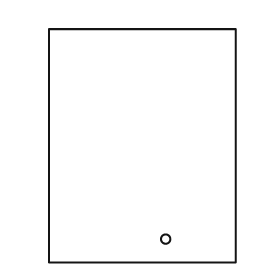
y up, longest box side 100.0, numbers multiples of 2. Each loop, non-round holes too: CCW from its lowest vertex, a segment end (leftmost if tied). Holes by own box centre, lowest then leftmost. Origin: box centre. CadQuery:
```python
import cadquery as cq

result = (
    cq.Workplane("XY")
    .moveTo(-40.0, -50.0)
    .lineTo(40.0, -50.0)
    .lineTo(40.0, 50.0)
    .lineTo(-40.0, 50.0)
    .close()
    .moveTo(10.0, -40.0)
    .circle(2.0)
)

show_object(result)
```